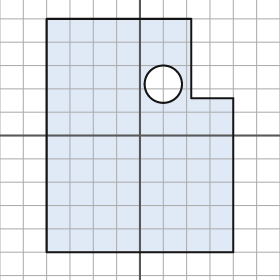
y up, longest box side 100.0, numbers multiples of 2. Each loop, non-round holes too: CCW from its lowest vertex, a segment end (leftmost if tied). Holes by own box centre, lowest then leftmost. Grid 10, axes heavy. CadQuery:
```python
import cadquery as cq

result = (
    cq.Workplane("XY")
    .moveTo(-40.0, -50.0)
    .lineTo(40.0, -50.0)
    .lineTo(40.0, 16.0)
    .lineTo(22.0, 16.0)
    .lineTo(22.0, 50.0)
    .lineTo(-40.0, 50.0)
    .close()
    .moveTo(10.0, 22.0)
    .circle(8.0)
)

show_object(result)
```